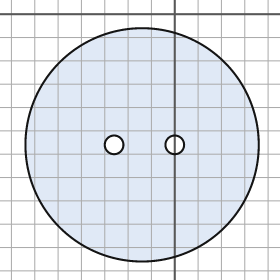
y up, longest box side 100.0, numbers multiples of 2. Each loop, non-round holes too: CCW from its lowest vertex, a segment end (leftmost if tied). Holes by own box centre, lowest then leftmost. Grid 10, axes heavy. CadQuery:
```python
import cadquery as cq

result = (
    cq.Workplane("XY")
    .moveTo(-14.0, -56.0)
    .circle(50.0)
    .moveTo(-26.0, -56.0)
    .circle(4.0)
    .moveTo(0.0, -56.0)
    .circle(4.0)
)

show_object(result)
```